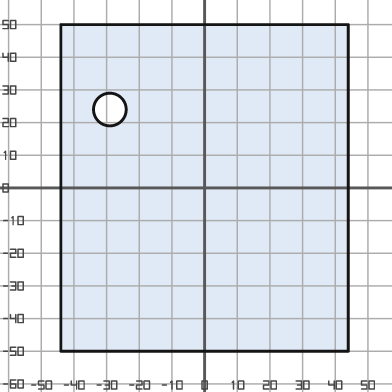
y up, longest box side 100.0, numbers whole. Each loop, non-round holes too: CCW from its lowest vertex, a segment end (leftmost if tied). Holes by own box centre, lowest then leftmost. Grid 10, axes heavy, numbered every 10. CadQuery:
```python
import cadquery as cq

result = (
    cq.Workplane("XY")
    .moveTo(-44.0, -50.0)
    .lineTo(44.0, -50.0)
    .lineTo(44.0, 50.0)
    .lineTo(-44.0, 50.0)
    .close()
    .moveTo(-29.0, 24.0)
    .circle(5.0)
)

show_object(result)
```